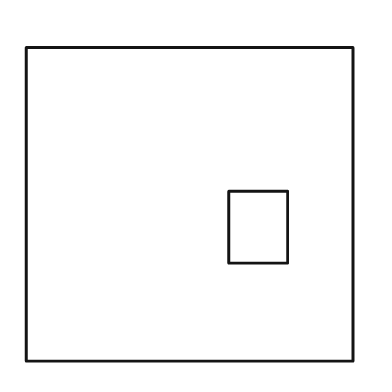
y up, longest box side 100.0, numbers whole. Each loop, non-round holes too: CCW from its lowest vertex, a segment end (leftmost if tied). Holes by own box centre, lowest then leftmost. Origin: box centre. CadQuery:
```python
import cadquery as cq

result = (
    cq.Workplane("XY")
    .moveTo(-50.0, -48.0)
    .lineTo(50.0, -48.0)
    .lineTo(50.0, 48.0)
    .lineTo(-50.0, 48.0)
    .close()
    .moveTo(12.0, -18.0)
    .lineTo(30.0, -18.0)
    .lineTo(30.0, 4.0)
    .lineTo(12.0, 4.0)
    .close()
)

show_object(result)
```